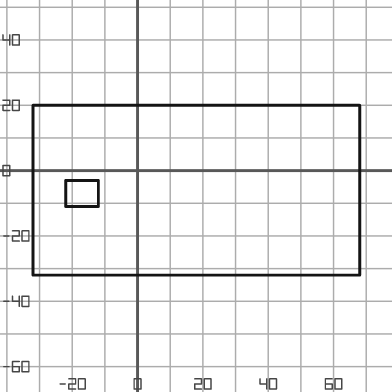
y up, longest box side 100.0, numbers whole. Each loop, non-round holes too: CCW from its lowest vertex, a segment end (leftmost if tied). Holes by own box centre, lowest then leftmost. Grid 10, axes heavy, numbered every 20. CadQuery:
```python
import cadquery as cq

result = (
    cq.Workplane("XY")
    .moveTo(-32.0, -32.0)
    .lineTo(68.0, -32.0)
    .lineTo(68.0, 20.0)
    .lineTo(-32.0, 20.0)
    .close()
    .moveTo(-22.0, -11.0)
    .lineTo(-12.0, -11.0)
    .lineTo(-12.0, -3.0)
    .lineTo(-22.0, -3.0)
    .close()
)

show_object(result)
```